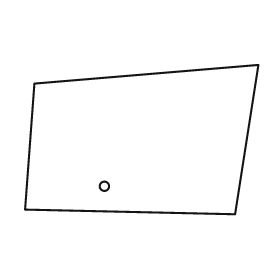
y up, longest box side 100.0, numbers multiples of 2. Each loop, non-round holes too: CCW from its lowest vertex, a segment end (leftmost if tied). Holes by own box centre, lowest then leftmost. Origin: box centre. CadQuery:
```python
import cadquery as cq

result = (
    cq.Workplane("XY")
    .moveTo(40.0, -32.0)
    .lineTo(50.0, 32.0)
    .lineTo(-46.0, 24.0)
    .lineTo(-50.0, -30.0)
    .close()
    .moveTo(-16.0, -20.0)
    .circle(2.0)
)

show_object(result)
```